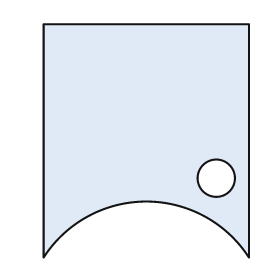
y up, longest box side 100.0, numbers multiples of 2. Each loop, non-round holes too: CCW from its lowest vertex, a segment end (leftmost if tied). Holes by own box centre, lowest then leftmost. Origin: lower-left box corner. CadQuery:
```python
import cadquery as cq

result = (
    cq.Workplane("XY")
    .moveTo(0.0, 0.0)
    .threePointArc((44.0, 24.0), (88.0, 0.0))
    .lineTo(88.0, 100.0)
    .lineTo(0.0, 100.0)
    .close()
    .moveTo(74.0, 34.0)
    .circle(8.0)
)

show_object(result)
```